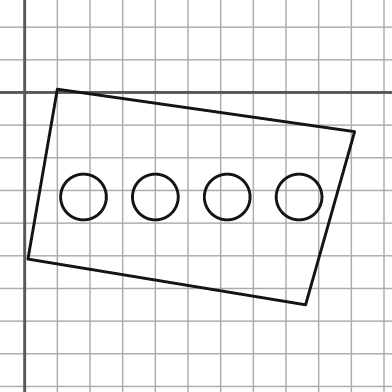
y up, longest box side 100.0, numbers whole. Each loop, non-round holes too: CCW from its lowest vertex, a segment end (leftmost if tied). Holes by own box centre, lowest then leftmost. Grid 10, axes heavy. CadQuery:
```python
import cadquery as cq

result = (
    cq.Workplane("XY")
    .moveTo(86.0, -65.0)
    .lineTo(101.0, -12.0)
    .lineTo(10.0, 1.0)
    .lineTo(1.0, -51.0)
    .close()
    .moveTo(18.0, -32.0)
    .circle(7.0)
    .moveTo(40.0, -32.0)
    .circle(7.0)
    .moveTo(62.0, -32.0)
    .circle(7.0)
    .moveTo(84.0, -32.0)
    .circle(7.0)
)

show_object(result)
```